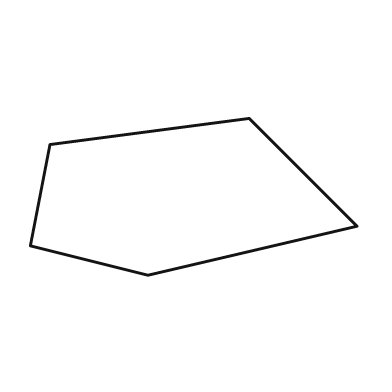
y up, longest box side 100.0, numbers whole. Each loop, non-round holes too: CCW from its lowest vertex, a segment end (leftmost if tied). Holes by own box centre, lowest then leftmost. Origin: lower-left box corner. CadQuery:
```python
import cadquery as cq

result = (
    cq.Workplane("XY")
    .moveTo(36.0, 0.0)
    .lineTo(100.0, 15.0)
    .lineTo(67.0, 48.0)
    .lineTo(6.0, 40.0)
    .lineTo(0.0, 9.0)
    .close()
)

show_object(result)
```